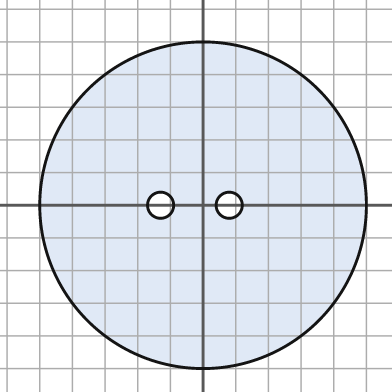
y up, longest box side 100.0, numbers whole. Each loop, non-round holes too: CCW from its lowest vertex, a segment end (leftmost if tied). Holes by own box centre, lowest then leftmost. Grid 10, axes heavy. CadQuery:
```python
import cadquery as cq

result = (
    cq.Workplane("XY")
    .moveTo(0.0, 0.0)
    .circle(50.0)
    .moveTo(-13.0, 0.0)
    .circle(4.0)
    .moveTo(8.0, 0.0)
    .circle(4.0)
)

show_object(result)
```